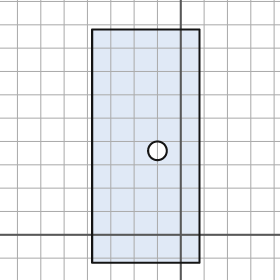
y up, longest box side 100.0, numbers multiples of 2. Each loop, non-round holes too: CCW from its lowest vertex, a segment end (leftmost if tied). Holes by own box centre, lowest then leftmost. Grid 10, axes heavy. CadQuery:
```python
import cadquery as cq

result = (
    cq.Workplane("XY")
    .moveTo(-38.0, -12.0)
    .lineTo(8.0, -12.0)
    .lineTo(8.0, 88.0)
    .lineTo(-38.0, 88.0)
    .close()
    .moveTo(-10.0, 36.0)
    .circle(4.0)
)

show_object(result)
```